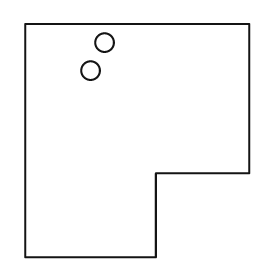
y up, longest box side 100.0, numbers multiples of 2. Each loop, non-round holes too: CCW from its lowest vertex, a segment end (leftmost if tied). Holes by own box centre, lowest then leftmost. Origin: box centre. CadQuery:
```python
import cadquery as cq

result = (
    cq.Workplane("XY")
    .moveTo(-48.0, -50.0)
    .lineTo(8.0, -50.0)
    .lineTo(8.0, -14.0)
    .lineTo(48.0, -14.0)
    .lineTo(48.0, 50.0)
    .lineTo(-48.0, 50.0)
    .close()
    .moveTo(-20.0, 30.0)
    .circle(4.0)
    .moveTo(-14.0, 42.0)
    .circle(4.0)
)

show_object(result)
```